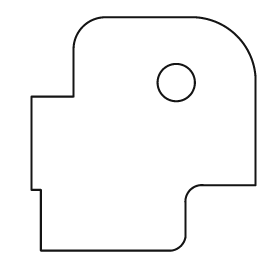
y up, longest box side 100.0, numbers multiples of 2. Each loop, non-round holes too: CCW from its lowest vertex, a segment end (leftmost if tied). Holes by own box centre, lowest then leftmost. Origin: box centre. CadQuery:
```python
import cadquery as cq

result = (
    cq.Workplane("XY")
    .moveTo(-44.0, -50.0)
    .lineTo(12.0, -50.0)
    .threePointArc((16.0, -48.0), (18.0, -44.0))
    .lineTo(18.0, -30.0)
    .threePointArc((20.0, -24.0), (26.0, -22.0))
    .lineTo(48.0, -22.0)
    .lineTo(48.0, 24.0)
    .threePointArc((40.0, 42.0), (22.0, 50.0))
    .lineTo(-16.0, 50.0)
    .threePointArc((-26.0, 46.0), (-30.0, 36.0))
    .lineTo(-30.0, 16.0)
    .lineTo(-48.0, 16.0)
    .lineTo(-48.0, -24.0)
    .lineTo(-44.0, -24.0)
    .close()
    .moveTo(14.0, 22.0)
    .circle(8.0)
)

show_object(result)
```